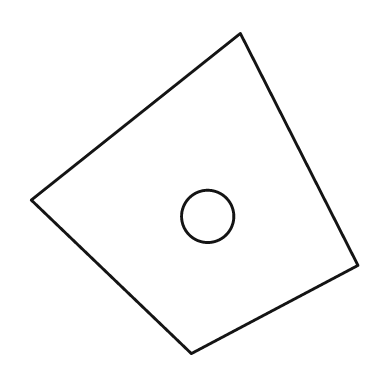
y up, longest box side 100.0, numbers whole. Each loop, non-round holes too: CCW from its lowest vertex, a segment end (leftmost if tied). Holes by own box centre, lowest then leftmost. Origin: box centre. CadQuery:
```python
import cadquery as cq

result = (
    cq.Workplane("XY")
    .moveTo(-1.0, -49.0)
    .lineTo(50.0, -22.0)
    .lineTo(14.0, 49.0)
    .lineTo(-50.0, -2.0)
    .close()
    .moveTo(4.0, -7.0)
    .circle(8.0)
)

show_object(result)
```